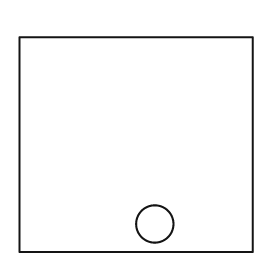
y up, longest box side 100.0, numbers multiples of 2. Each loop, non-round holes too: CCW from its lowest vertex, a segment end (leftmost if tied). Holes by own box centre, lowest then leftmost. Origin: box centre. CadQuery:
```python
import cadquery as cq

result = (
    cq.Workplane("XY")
    .moveTo(-50.0, -46.0)
    .lineTo(50.0, -46.0)
    .lineTo(50.0, 46.0)
    .lineTo(-50.0, 46.0)
    .close()
    .moveTo(8.0, -34.0)
    .circle(8.0)
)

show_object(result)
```